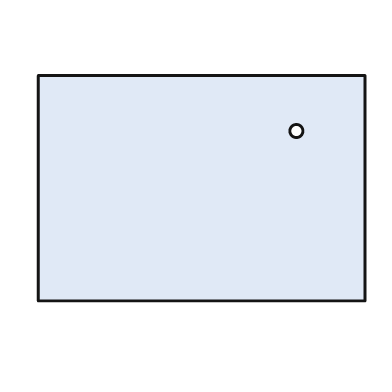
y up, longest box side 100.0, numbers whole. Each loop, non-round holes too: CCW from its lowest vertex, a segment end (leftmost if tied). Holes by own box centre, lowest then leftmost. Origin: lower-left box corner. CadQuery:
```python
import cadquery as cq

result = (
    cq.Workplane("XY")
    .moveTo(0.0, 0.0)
    .lineTo(100.0, 0.0)
    .lineTo(100.0, 69.0)
    .lineTo(0.0, 69.0)
    .close()
    .moveTo(79.0, 52.0)
    .circle(2.0)
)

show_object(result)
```